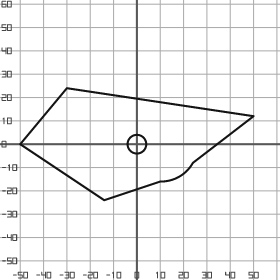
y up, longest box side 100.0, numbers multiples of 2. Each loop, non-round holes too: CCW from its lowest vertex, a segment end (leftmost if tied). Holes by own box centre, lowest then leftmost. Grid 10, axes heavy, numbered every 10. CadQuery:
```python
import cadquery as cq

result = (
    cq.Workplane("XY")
    .moveTo(-14.0, -24.0)
    .lineTo(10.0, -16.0)
    .threePointArc((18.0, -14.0), (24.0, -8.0))
    .lineTo(50.0, 12.0)
    .lineTo(-30.0, 24.0)
    .lineTo(-50.0, 0.0)
    .close()
    .moveTo(0.0, 0.0)
    .circle(4.0)
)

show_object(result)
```